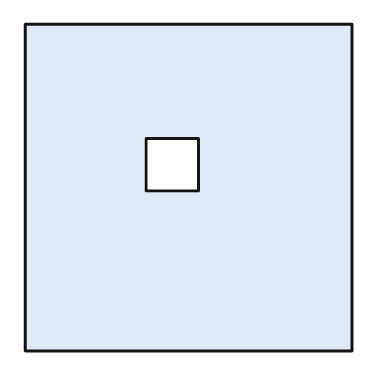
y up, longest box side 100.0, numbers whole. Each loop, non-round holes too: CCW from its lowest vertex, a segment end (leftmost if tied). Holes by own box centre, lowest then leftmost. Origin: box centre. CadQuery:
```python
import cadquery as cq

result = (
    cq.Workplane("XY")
    .moveTo(-50.0, -50.0)
    .lineTo(50.0, -50.0)
    .lineTo(50.0, 50.0)
    .lineTo(-50.0, 50.0)
    .close()
    .moveTo(-13.0, -1.0)
    .lineTo(3.0, -1.0)
    .lineTo(3.0, 15.0)
    .lineTo(-13.0, 15.0)
    .close()
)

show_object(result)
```